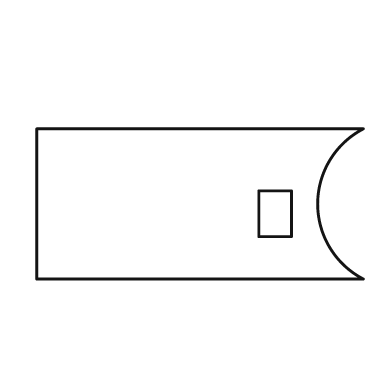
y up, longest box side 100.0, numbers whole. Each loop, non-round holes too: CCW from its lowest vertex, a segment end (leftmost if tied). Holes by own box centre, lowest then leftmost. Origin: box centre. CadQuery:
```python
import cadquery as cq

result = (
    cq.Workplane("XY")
    .moveTo(-50.0, -23.0)
    .lineTo(50.0, -23.0)
    .threePointArc((36.0, 0.0), (50.0, 23.0))
    .lineTo(-50.0, 23.0)
    .close()
    .moveTo(18.0, -10.0)
    .lineTo(28.0, -10.0)
    .lineTo(28.0, 4.0)
    .lineTo(18.0, 4.0)
    .close()
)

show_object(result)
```